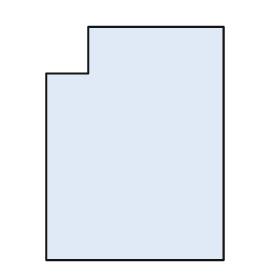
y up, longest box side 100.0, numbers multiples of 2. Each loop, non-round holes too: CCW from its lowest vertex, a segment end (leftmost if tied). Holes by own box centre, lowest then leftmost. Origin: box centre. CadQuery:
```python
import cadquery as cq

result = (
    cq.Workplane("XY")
    .moveTo(-38.0, -50.0)
    .lineTo(38.0, -50.0)
    .lineTo(38.0, 50.0)
    .lineTo(-20.0, 50.0)
    .lineTo(-20.0, 30.0)
    .lineTo(-38.0, 30.0)
    .close()
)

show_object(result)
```